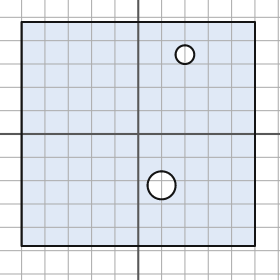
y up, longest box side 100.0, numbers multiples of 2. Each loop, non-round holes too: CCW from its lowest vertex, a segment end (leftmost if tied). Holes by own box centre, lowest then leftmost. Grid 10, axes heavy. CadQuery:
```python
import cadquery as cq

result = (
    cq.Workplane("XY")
    .moveTo(-50.0, -48.0)
    .lineTo(50.0, -48.0)
    .lineTo(50.0, 48.0)
    .lineTo(-50.0, 48.0)
    .close()
    .moveTo(10.0, -22.0)
    .circle(6.0)
    .moveTo(20.0, 34.0)
    .circle(4.0)
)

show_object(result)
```